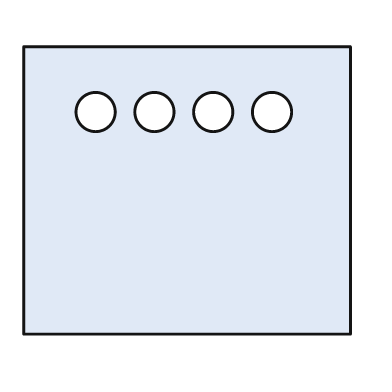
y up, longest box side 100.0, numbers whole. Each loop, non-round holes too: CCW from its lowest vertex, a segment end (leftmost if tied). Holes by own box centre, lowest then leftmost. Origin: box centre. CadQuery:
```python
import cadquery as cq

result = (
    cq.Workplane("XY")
    .moveTo(-50.0, -44.0)
    .lineTo(50.0, -44.0)
    .lineTo(50.0, 44.0)
    .lineTo(-50.0, 44.0)
    .close()
    .moveTo(-28.0, 24.0)
    .circle(6.0)
    .moveTo(-10.0, 24.0)
    .circle(6.0)
    .moveTo(8.0, 24.0)
    .circle(6.0)
    .moveTo(26.0, 24.0)
    .circle(6.0)
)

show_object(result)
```